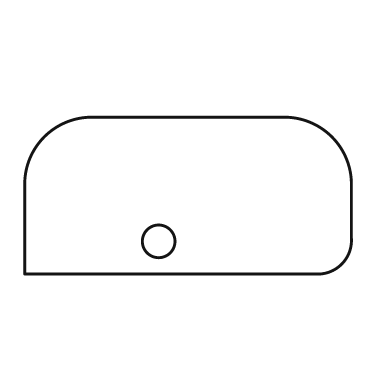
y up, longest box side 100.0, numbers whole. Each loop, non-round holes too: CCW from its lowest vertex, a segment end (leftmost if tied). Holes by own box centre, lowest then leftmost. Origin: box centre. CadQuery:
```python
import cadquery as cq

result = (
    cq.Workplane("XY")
    .moveTo(-50.0, -24.0)
    .lineTo(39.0, -24.0)
    .threePointArc((47.0, -21.0), (50.0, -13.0))
    .lineTo(50.0, 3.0)
    .threePointArc((44.0, 18.0), (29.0, 24.0))
    .lineTo(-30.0, 24.0)
    .threePointArc((-44.0, 18.0), (-50.0, 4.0))
    .close()
    .moveTo(-9.0, -14.0)
    .circle(5.0)
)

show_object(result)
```